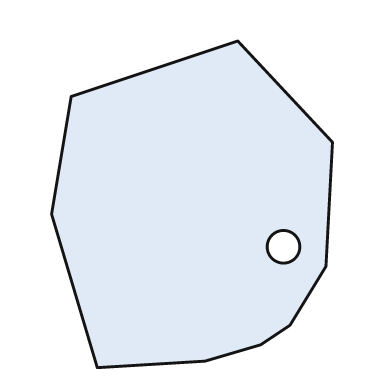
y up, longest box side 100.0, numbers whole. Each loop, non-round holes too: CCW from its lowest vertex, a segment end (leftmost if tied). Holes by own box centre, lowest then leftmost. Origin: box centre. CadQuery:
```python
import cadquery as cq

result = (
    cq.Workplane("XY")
    .moveTo(-29.0, -50.0)
    .lineTo(4.0, -48.0)
    .lineTo(21.0, -43.0)
    .lineTo(30.0, -37.0)
    .lineTo(41.0, -19.0)
    .lineTo(43.0, 19.0)
    .lineTo(14.0, 50.0)
    .lineTo(-37.0, 33.0)
    .lineTo(-43.0, -3.0)
    .close()
    .moveTo(28.0, -13.0)
    .circle(5.0)
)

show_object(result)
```